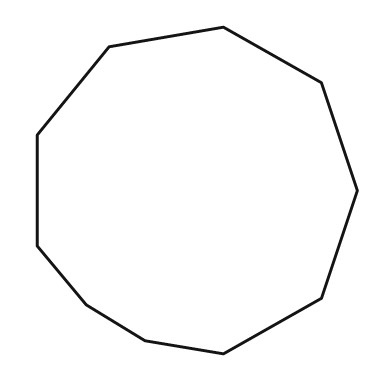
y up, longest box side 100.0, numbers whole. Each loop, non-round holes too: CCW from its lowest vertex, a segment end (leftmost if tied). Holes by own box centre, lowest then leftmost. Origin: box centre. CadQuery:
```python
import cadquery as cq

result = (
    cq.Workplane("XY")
    .moveTo(8.0, -50.0)
    .lineTo(38.0, -33.0)
    .lineTo(49.0, 0.0)
    .lineTo(38.0, 33.0)
    .lineTo(8.0, 50.0)
    .lineTo(-27.0, 44.0)
    .lineTo(-49.0, 17.0)
    .lineTo(-49.0, -17.0)
    .lineTo(-34.0, -35.0)
    .lineTo(-16.0, -46.0)
    .close()
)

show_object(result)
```